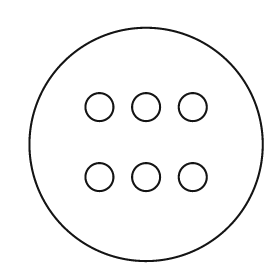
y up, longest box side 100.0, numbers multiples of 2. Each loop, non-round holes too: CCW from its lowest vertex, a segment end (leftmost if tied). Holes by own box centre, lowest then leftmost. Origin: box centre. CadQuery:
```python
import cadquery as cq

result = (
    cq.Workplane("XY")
    .moveTo(0.0, 0.0)
    .circle(50.0)
    .moveTo(-20.0, -14.0)
    .circle(6.0)
    .moveTo(0.0, -14.0)
    .circle(6.0)
    .moveTo(20.0, -14.0)
    .circle(6.0)
    .moveTo(-20.0, 16.0)
    .circle(6.0)
    .moveTo(0.0, 16.0)
    .circle(6.0)
    .moveTo(20.0, 16.0)
    .circle(6.0)
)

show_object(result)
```